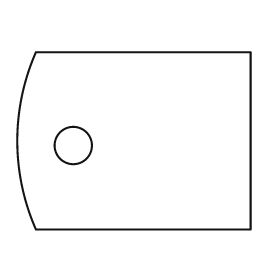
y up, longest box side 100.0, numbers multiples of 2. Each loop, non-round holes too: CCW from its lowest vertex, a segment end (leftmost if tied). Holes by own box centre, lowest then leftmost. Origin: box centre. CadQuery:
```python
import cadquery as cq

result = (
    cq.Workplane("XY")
    .moveTo(-42.0, -38.0)
    .lineTo(50.0, -38.0)
    .lineTo(50.0, 38.0)
    .lineTo(-42.0, 38.0)
    .threePointArc((-50.0, 0.0), (-42.0, -38.0))
    .close()
    .moveTo(-26.0, -2.0)
    .circle(8.0)
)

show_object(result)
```